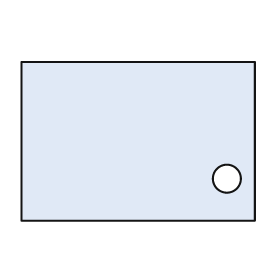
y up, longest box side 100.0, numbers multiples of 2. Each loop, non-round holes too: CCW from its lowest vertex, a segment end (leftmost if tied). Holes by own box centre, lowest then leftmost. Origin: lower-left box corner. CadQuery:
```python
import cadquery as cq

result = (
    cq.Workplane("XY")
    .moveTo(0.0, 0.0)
    .lineTo(100.0, 0.0)
    .lineTo(100.0, 68.0)
    .lineTo(0.0, 68.0)
    .close()
    .moveTo(88.0, 18.0)
    .circle(6.0)
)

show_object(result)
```